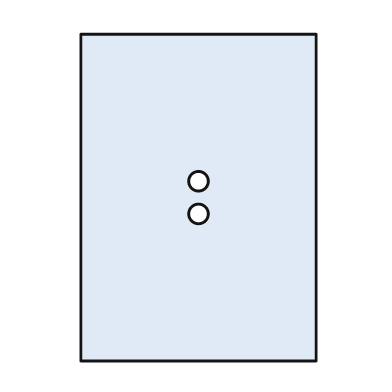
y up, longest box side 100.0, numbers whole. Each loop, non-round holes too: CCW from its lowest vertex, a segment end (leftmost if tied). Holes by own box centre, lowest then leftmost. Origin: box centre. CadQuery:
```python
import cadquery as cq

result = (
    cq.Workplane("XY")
    .moveTo(-36.0, -50.0)
    .lineTo(36.0, -50.0)
    .lineTo(36.0, 50.0)
    .lineTo(-36.0, 50.0)
    .close()
    .moveTo(0.0, -5.0)
    .circle(3.0)
    .moveTo(0.0, 5.0)
    .circle(3.0)
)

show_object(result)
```